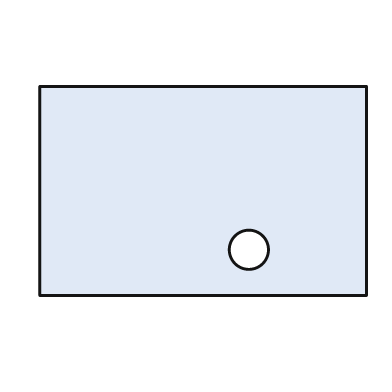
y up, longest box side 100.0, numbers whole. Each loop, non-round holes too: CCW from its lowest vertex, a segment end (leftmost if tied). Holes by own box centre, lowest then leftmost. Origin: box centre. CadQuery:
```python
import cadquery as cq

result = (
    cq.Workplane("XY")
    .moveTo(-50.0, -32.0)
    .lineTo(50.0, -32.0)
    .lineTo(50.0, 32.0)
    .lineTo(-50.0, 32.0)
    .close()
    .moveTo(14.0, -18.0)
    .circle(6.0)
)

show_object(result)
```